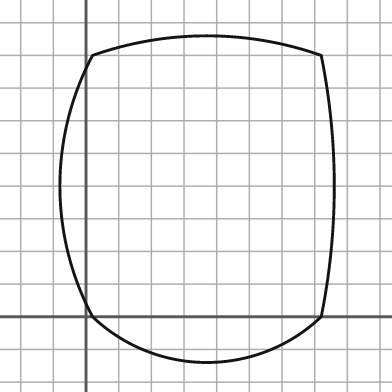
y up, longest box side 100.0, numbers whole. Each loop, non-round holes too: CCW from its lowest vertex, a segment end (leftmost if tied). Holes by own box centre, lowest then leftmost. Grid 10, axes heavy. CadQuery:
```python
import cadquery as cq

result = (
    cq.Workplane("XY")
    .moveTo(2.0, 0.0)
    .threePointArc((37.0, -14.0), (72.0, 0.0))
    .threePointArc((76.0, 40.0), (72.0, 80.0))
    .threePointArc((37.0, 86.0), (2.0, 80.0))
    .threePointArc((-8.0, 40.0), (2.0, 0.0))
    .close()
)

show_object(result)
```